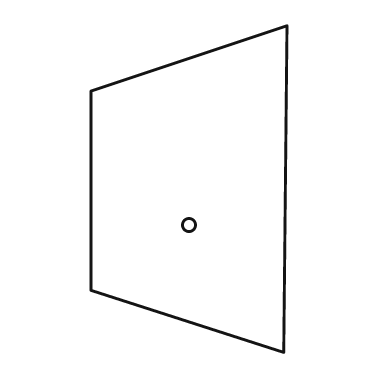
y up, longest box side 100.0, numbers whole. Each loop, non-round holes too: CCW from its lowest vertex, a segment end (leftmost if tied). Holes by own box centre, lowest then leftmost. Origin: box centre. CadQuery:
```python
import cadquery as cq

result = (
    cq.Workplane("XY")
    .moveTo(29.0, -50.0)
    .lineTo(30.0, 50.0)
    .lineTo(-30.0, 30.0)
    .lineTo(-30.0, -31.0)
    .close()
    .moveTo(0.0, -11.0)
    .circle(2.0)
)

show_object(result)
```